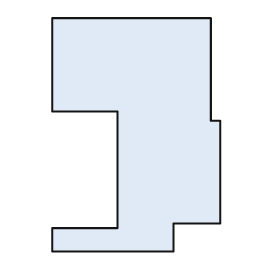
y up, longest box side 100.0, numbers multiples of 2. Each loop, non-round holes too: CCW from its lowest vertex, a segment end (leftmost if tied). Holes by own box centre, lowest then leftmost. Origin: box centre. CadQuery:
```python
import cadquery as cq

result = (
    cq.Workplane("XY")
    .moveTo(-36.0, -50.0)
    .lineTo(16.0, -50.0)
    .lineTo(16.0, -38.0)
    .lineTo(36.0, -38.0)
    .lineTo(36.0, 6.0)
    .lineTo(32.0, 6.0)
    .lineTo(32.0, 50.0)
    .lineTo(-36.0, 50.0)
    .lineTo(-36.0, 10.0)
    .lineTo(-8.0, 10.0)
    .lineTo(-8.0, -40.0)
    .lineTo(-36.0, -40.0)
    .close()
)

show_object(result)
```